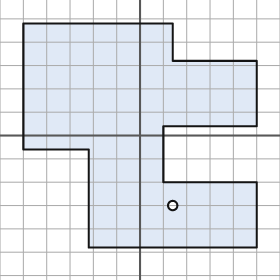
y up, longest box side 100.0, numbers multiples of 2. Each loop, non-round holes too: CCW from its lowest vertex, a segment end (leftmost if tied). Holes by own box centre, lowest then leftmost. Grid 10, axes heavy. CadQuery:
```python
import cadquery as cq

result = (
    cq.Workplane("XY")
    .moveTo(-22.0, -48.0)
    .lineTo(50.0, -48.0)
    .lineTo(50.0, -20.0)
    .lineTo(10.0, -20.0)
    .lineTo(10.0, 4.0)
    .lineTo(50.0, 4.0)
    .lineTo(50.0, 32.0)
    .lineTo(14.0, 32.0)
    .lineTo(14.0, 48.0)
    .lineTo(-50.0, 48.0)
    .lineTo(-50.0, -6.0)
    .lineTo(-22.0, -6.0)
    .close()
    .moveTo(14.0, -30.0)
    .circle(2.0)
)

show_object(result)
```